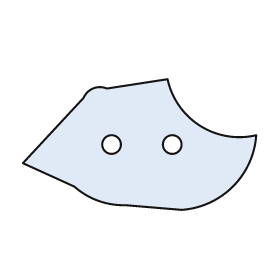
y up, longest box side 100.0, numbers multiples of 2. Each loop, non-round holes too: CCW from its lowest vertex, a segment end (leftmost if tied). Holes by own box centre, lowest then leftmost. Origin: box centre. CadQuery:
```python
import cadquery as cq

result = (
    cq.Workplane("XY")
    .moveTo(18.0, -28.0)
    .threePointArc((40.0, -18.0), (50.0, 4.0))
    .threePointArc((26.0, 8.0), (12.0, 28.0))
    .lineTo(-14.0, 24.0)
    .threePointArc((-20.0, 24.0), (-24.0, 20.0))
    .lineTo(-50.0, -8.0)
    .lineTo(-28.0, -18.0)
    .threePointArc((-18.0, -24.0), (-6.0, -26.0))
    .close()
    .moveTo(-12.0, 0.0)
    .circle(4.0)
    .moveTo(14.0, 0.0)
    .circle(4.0)
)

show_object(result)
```